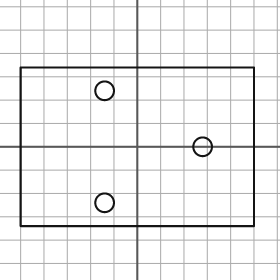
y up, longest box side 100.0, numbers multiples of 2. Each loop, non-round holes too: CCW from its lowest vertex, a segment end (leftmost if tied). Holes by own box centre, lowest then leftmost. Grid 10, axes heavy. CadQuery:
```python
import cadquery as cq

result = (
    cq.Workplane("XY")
    .moveTo(-50.0, -34.0)
    .lineTo(50.0, -34.0)
    .lineTo(50.0, 34.0)
    .lineTo(-50.0, 34.0)
    .close()
    .moveTo(-14.0, -24.0)
    .circle(4.0)
    .moveTo(28.0, 0.0)
    .circle(4.0)
    .moveTo(-14.0, 24.0)
    .circle(4.0)
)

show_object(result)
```